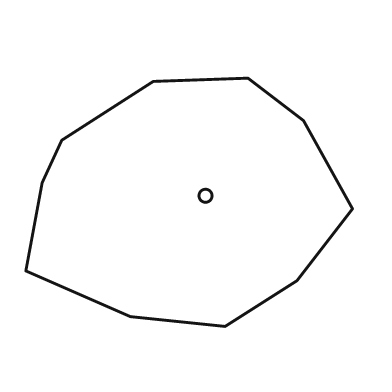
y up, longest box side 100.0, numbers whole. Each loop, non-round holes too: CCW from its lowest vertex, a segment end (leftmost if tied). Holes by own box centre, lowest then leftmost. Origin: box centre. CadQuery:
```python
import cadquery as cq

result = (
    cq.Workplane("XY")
    .moveTo(11.0, -38.0)
    .lineTo(33.0, -24.0)
    .lineTo(50.0, -2.0)
    .lineTo(35.0, 25.0)
    .lineTo(18.0, 38.0)
    .lineTo(-11.0, 37.0)
    .lineTo(-39.0, 19.0)
    .lineTo(-45.0, 6.0)
    .lineTo(-50.0, -21.0)
    .lineTo(-18.0, -35.0)
    .close()
    .moveTo(5.0, 2.0)
    .circle(2.0)
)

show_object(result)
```